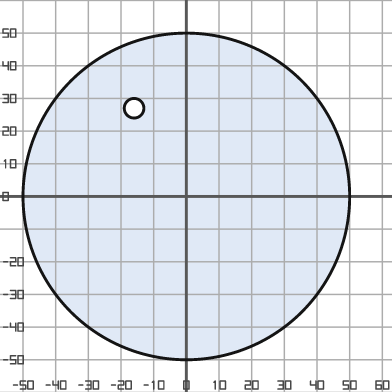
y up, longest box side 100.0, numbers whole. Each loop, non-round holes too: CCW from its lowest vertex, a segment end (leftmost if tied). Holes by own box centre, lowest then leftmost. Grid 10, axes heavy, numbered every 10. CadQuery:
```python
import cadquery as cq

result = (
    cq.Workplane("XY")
    .moveTo(0.0, 0.0)
    .circle(50.0)
    .moveTo(-16.0, 27.0)
    .circle(3.0)
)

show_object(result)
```